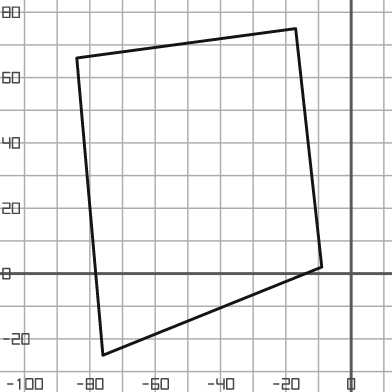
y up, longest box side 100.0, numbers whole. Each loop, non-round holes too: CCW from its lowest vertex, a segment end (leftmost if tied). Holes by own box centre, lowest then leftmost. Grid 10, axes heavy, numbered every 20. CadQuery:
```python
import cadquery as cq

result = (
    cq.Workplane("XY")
    .moveTo(-76.0, -25.0)
    .lineTo(-9.0, 2.0)
    .lineTo(-17.0, 75.0)
    .lineTo(-84.0, 66.0)
    .close()
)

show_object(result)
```